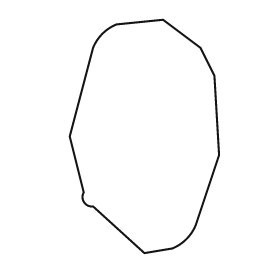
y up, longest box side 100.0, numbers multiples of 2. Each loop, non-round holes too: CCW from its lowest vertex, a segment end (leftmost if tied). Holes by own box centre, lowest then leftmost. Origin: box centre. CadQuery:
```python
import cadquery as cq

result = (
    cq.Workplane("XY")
    .moveTo(0.0, -50.0)
    .lineTo(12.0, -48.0)
    .threePointArc((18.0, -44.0), (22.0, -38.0))
    .lineTo(32.0, -8.0)
    .lineTo(30.0, 26.0)
    .lineTo(24.0, 38.0)
    .lineTo(8.0, 50.0)
    .lineTo(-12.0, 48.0)
    .threePointArc((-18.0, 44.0), (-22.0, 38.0))
    .lineTo(-32.0, 0.0)
    .lineTo(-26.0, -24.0)
    .threePointArc((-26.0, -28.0), (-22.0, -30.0))
    .close()
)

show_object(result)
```